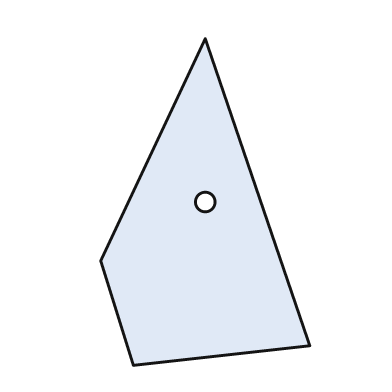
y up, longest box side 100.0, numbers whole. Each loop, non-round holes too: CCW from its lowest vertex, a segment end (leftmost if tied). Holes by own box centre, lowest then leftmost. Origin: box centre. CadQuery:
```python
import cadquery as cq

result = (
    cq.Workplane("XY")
    .moveTo(-22.0, -50.0)
    .lineTo(32.0, -44.0)
    .lineTo(0.0, 50.0)
    .lineTo(-32.0, -18.0)
    .close()
    .moveTo(0.0, 0.0)
    .circle(3.0)
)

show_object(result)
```